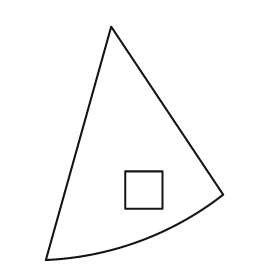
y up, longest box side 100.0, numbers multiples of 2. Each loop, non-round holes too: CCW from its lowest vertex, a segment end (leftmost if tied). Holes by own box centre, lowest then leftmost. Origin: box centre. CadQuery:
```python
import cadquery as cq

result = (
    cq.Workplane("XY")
    .moveTo(-38.0, -50.0)
    .threePointArc((2.0, -42.0), (38.0, -22.0))
    .lineTo(-10.0, 50.0)
    .close()
    .moveTo(-4.0, -28.0)
    .lineTo(12.0, -28.0)
    .lineTo(12.0, -12.0)
    .lineTo(-4.0, -12.0)
    .close()
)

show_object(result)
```